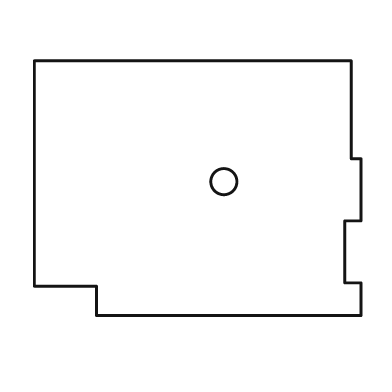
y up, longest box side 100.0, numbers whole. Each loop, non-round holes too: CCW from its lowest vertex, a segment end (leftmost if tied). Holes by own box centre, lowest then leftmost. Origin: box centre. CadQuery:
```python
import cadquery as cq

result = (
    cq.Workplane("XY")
    .moveTo(-31.0, -39.0)
    .lineTo(50.0, -39.0)
    .lineTo(50.0, -29.0)
    .lineTo(45.0, -29.0)
    .lineTo(45.0, -10.0)
    .lineTo(50.0, -10.0)
    .lineTo(50.0, 9.0)
    .lineTo(47.0, 9.0)
    .lineTo(47.0, 39.0)
    .lineTo(-50.0, 39.0)
    .lineTo(-50.0, -30.0)
    .lineTo(-31.0, -30.0)
    .close()
    .moveTo(8.0, 2.0)
    .circle(4.0)
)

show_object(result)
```